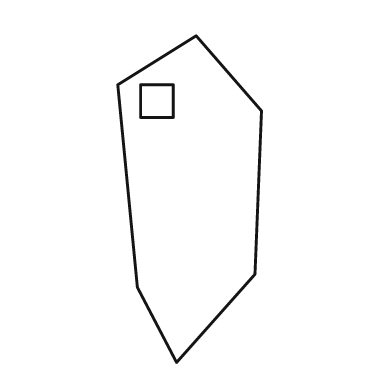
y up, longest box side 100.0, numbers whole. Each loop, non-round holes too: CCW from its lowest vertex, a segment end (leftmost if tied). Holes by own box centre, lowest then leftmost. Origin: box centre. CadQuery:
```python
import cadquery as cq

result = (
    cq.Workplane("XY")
    .moveTo(-4.0, -50.0)
    .lineTo(20.0, -23.0)
    .lineTo(22.0, 27.0)
    .lineTo(2.0, 50.0)
    .lineTo(-22.0, 35.0)
    .lineTo(-16.0, -27.0)
    .close()
    .moveTo(-15.0, 25.0)
    .lineTo(-5.0, 25.0)
    .lineTo(-5.0, 35.0)
    .lineTo(-15.0, 35.0)
    .close()
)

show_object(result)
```